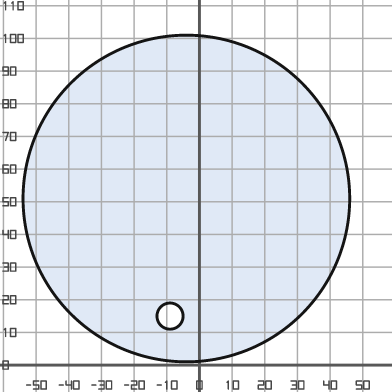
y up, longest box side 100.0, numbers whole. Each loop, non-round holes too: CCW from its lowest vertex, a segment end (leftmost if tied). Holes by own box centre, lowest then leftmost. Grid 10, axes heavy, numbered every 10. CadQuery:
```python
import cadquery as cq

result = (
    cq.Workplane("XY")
    .moveTo(-4.0, 51.0)
    .circle(50.0)
    .moveTo(-9.0, 15.0)
    .circle(4.0)
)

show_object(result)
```